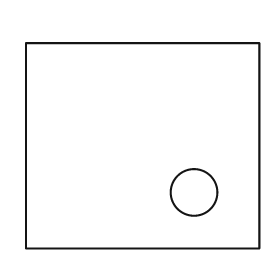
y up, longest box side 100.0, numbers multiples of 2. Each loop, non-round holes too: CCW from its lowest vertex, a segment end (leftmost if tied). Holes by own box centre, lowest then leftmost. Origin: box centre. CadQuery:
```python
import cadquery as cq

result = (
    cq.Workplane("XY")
    .moveTo(-50.0, -44.0)
    .lineTo(50.0, -44.0)
    .lineTo(50.0, 44.0)
    .lineTo(-50.0, 44.0)
    .close()
    .moveTo(22.0, -20.0)
    .circle(10.0)
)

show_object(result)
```